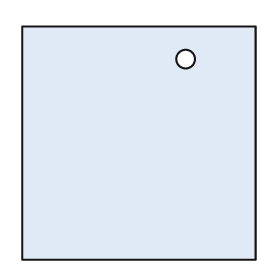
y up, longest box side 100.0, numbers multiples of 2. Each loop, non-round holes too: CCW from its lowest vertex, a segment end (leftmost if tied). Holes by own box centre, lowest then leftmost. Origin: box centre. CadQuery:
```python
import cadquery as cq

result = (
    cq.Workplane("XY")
    .moveTo(-50.0, -50.0)
    .lineTo(50.0, -50.0)
    .lineTo(50.0, 50.0)
    .lineTo(-50.0, 50.0)
    .close()
    .moveTo(20.0, 36.0)
    .circle(4.0)
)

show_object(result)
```